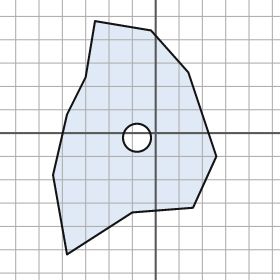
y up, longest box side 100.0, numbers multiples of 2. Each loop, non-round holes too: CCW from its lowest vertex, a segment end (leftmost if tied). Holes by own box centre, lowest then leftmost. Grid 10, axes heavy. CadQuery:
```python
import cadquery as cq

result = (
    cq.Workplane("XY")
    .moveTo(-38.0, -52.0)
    .lineTo(-10.0, -34.0)
    .lineTo(16.0, -32.0)
    .lineTo(26.0, -10.0)
    .lineTo(14.0, 26.0)
    .lineTo(-2.0, 44.0)
    .lineTo(-26.0, 48.0)
    .lineTo(-30.0, 24.0)
    .lineTo(-38.0, 8.0)
    .lineTo(-44.0, -18.0)
    .close()
    .moveTo(-8.0, -2.0)
    .circle(6.0)
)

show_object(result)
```